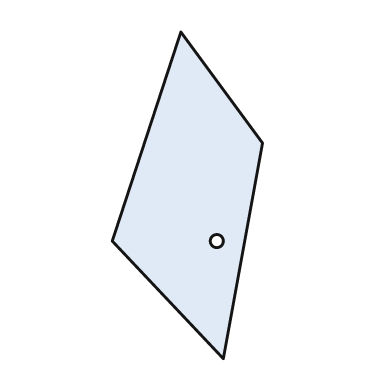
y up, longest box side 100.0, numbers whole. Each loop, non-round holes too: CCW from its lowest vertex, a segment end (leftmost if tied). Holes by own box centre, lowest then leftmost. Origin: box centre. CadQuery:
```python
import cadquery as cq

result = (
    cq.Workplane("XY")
    .moveTo(11.0, -50.0)
    .lineTo(23.0, 16.0)
    .lineTo(-2.0, 50.0)
    .lineTo(-23.0, -14.0)
    .close()
    .moveTo(9.0, -14.0)
    .circle(2.0)
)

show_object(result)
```